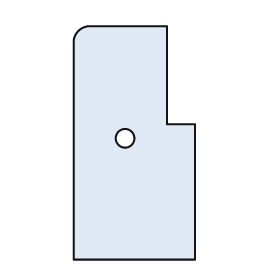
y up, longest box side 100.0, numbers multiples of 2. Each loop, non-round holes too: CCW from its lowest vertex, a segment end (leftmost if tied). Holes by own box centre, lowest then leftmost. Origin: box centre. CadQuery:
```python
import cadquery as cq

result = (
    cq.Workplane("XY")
    .moveTo(-26.0, -50.0)
    .lineTo(26.0, -50.0)
    .lineTo(26.0, 8.0)
    .lineTo(14.0, 8.0)
    .lineTo(14.0, 50.0)
    .lineTo(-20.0, 50.0)
    .threePointArc((-24.0, 48.0), (-26.0, 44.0))
    .close()
    .moveTo(-4.0, 2.0)
    .circle(4.0)
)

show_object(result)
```